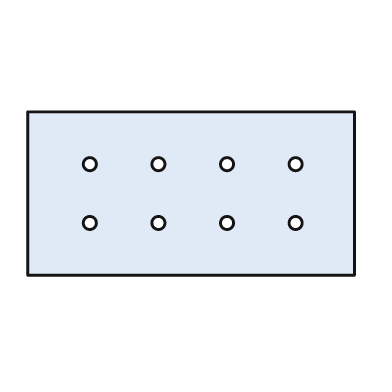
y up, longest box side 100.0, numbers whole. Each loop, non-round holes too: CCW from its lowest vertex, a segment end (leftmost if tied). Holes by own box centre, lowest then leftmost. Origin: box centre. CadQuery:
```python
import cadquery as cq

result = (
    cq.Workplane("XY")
    .moveTo(-50.0, -25.0)
    .lineTo(50.0, -25.0)
    .lineTo(50.0, 25.0)
    .lineTo(-50.0, 25.0)
    .close()
    .moveTo(-31.0, -9.0)
    .circle(2.0)
    .moveTo(-10.0, -9.0)
    .circle(2.0)
    .moveTo(11.0, -9.0)
    .circle(2.0)
    .moveTo(32.0, -9.0)
    .circle(2.0)
    .moveTo(-31.0, 9.0)
    .circle(2.0)
    .moveTo(-10.0, 9.0)
    .circle(2.0)
    .moveTo(11.0, 9.0)
    .circle(2.0)
    .moveTo(32.0, 9.0)
    .circle(2.0)
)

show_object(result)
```